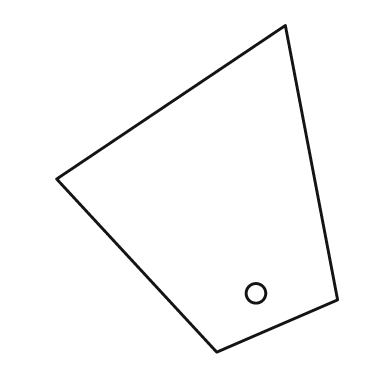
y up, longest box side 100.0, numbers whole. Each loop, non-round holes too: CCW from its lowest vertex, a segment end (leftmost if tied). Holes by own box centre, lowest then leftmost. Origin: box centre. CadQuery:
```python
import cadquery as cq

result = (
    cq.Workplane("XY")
    .moveTo(6.0, -50.0)
    .lineTo(43.0, -34.0)
    .lineTo(27.0, 50.0)
    .lineTo(-43.0, 3.0)
    .close()
    .moveTo(18.0, -32.0)
    .circle(3.0)
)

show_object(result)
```